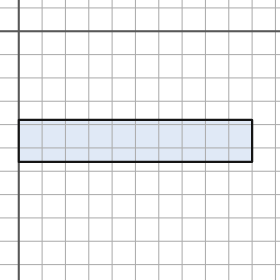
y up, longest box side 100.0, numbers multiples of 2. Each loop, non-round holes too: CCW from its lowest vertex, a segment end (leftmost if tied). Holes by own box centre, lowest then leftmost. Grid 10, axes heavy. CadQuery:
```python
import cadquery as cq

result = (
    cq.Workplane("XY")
    .moveTo(0.0, -56.0)
    .lineTo(100.0, -56.0)
    .lineTo(100.0, -38.0)
    .lineTo(0.0, -38.0)
    .close()
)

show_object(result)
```